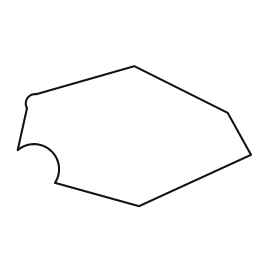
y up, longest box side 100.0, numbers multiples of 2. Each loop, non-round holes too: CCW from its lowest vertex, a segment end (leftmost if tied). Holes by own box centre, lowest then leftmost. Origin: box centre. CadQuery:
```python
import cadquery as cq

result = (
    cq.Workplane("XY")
    .moveTo(2.0, -30.0)
    .lineTo(50.0, -8.0)
    .lineTo(40.0, 10.0)
    .lineTo(0.0, 30.0)
    .lineTo(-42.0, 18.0)
    .threePointArc((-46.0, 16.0), (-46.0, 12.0))
    .lineTo(-50.0, -6.0)
    .threePointArc((-36.0, -6.0), (-34.0, -20.0))
    .close()
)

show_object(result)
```